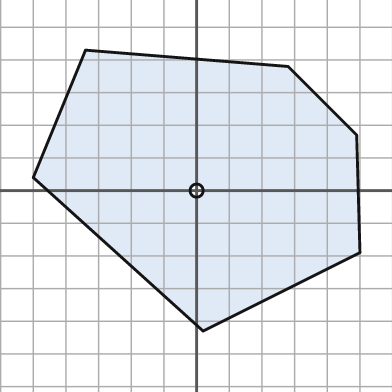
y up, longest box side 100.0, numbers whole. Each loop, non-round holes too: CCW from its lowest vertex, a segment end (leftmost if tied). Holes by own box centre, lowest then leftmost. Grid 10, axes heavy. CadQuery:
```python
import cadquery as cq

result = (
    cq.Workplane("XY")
    .moveTo(2.0, -43.0)
    .lineTo(50.0, -19.0)
    .lineTo(49.0, 17.0)
    .lineTo(28.0, 38.0)
    .lineTo(-34.0, 43.0)
    .lineTo(-50.0, 4.0)
    .close()
    .moveTo(0.0, 0.0)
    .circle(2.0)
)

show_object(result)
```